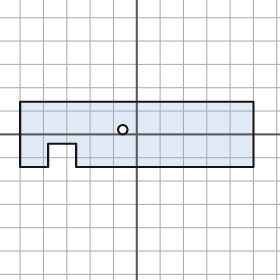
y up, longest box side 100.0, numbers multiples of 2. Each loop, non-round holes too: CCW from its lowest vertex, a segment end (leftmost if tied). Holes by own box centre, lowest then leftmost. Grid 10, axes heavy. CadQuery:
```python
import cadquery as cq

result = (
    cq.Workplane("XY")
    .moveTo(-50.0, -14.0)
    .lineTo(-38.0, -14.0)
    .lineTo(-38.0, -4.0)
    .lineTo(-26.0, -4.0)
    .lineTo(-26.0, -14.0)
    .lineTo(50.0, -14.0)
    .lineTo(50.0, 14.0)
    .lineTo(-50.0, 14.0)
    .close()
    .moveTo(-6.0, 2.0)
    .circle(2.0)
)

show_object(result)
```